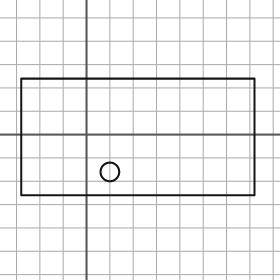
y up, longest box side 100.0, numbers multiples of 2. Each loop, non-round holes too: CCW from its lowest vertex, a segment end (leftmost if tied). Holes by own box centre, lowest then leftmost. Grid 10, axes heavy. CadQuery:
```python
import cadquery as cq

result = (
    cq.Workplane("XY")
    .moveTo(-28.0, -26.0)
    .lineTo(72.0, -26.0)
    .lineTo(72.0, 24.0)
    .lineTo(-28.0, 24.0)
    .close()
    .moveTo(10.0, -16.0)
    .circle(4.0)
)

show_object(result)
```